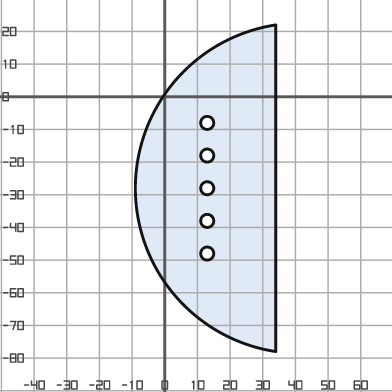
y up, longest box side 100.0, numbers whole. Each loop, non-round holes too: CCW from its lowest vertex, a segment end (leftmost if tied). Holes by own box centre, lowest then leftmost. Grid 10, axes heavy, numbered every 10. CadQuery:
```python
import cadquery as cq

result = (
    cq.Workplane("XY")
    .moveTo(34.0, -78.0)
    .lineTo(34.0, 22.0)
    .threePointArc((-9.0, -28.0), (34.0, -78.0))
    .close()
    .moveTo(13.0, -48.0)
    .circle(2.0)
    .moveTo(13.0, -38.0)
    .circle(2.0)
    .moveTo(13.0, -28.0)
    .circle(2.0)
    .moveTo(13.0, -18.0)
    .circle(2.0)
    .moveTo(13.0, -8.0)
    .circle(2.0)
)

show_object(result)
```